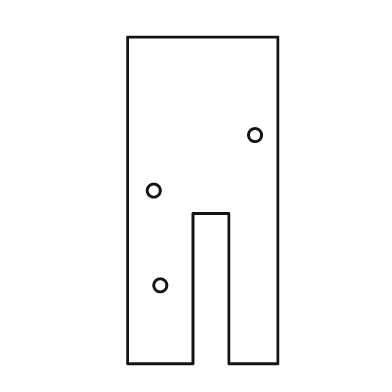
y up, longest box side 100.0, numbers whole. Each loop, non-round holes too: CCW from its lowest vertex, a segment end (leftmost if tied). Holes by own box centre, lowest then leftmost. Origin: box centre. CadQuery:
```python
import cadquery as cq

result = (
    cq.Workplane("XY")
    .moveTo(-23.0, -50.0)
    .lineTo(-3.0, -50.0)
    .lineTo(-3.0, -4.0)
    .lineTo(8.0, -4.0)
    .lineTo(8.0, -50.0)
    .lineTo(23.0, -50.0)
    .lineTo(23.0, 50.0)
    .lineTo(-23.0, 50.0)
    .close()
    .moveTo(-13.0, -26.0)
    .circle(2.0)
    .moveTo(-15.0, 3.0)
    .circle(2.0)
    .moveTo(16.0, 20.0)
    .circle(2.0)
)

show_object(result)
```